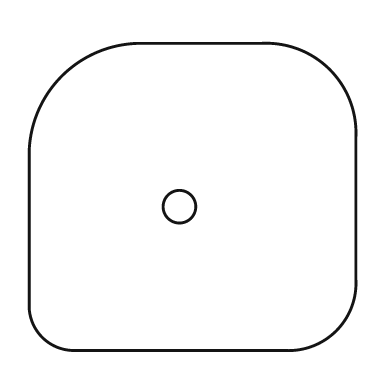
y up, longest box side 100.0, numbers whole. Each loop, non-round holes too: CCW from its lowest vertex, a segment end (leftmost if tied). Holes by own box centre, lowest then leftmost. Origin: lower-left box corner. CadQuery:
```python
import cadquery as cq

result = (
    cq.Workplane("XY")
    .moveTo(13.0, 0.0)
    .lineTo(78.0, 0.0)
    .threePointArc((94.0, 6.0), (100.0, 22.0))
    .lineTo(100.0, 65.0)
    .threePointArc((92.0, 86.0), (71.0, 94.0))
    .lineTo(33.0, 94.0)
    .threePointArc((10.0, 84.0), (0.0, 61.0))
    .lineTo(0.0, 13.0)
    .threePointArc((4.0, 4.0), (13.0, 0.0))
    .close()
    .moveTo(46.0, 44.0)
    .circle(5.0)
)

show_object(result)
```